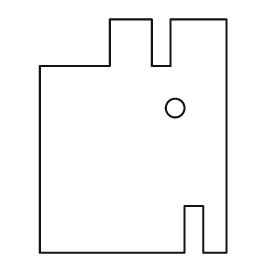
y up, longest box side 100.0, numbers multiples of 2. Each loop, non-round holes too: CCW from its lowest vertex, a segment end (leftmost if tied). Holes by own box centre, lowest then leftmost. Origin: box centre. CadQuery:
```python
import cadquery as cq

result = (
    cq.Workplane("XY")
    .moveTo(-40.0, -50.0)
    .lineTo(22.0, -50.0)
    .lineTo(22.0, -30.0)
    .lineTo(30.0, -30.0)
    .lineTo(30.0, -50.0)
    .lineTo(40.0, -50.0)
    .lineTo(40.0, 50.0)
    .lineTo(16.0, 50.0)
    .lineTo(16.0, 30.0)
    .lineTo(8.0, 30.0)
    .lineTo(8.0, 50.0)
    .lineTo(-10.0, 50.0)
    .lineTo(-10.0, 30.0)
    .lineTo(-40.0, 30.0)
    .close()
    .moveTo(18.0, 12.0)
    .circle(4.0)
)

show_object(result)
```